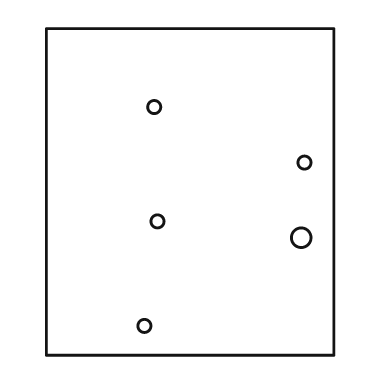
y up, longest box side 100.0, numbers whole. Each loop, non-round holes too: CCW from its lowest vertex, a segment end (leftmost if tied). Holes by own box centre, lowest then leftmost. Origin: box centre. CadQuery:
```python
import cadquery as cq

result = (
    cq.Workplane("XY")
    .moveTo(-44.0, -50.0)
    .lineTo(44.0, -50.0)
    .lineTo(44.0, 50.0)
    .lineTo(-44.0, 50.0)
    .close()
    .moveTo(-14.0, -41.0)
    .circle(2.0)
    .moveTo(34.0, -14.0)
    .circle(3.0)
    .moveTo(-10.0, -9.0)
    .circle(2.0)
    .moveTo(35.0, 9.0)
    .circle(2.0)
    .moveTo(-11.0, 26.0)
    .circle(2.0)
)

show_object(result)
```